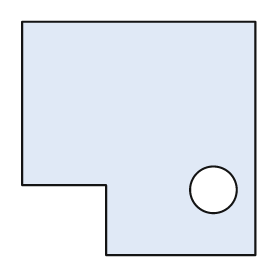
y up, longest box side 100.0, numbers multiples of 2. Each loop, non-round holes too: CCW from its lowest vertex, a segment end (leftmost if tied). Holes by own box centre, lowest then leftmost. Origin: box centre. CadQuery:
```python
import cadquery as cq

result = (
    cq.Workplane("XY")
    .moveTo(-14.0, -50.0)
    .lineTo(50.0, -50.0)
    .lineTo(50.0, 50.0)
    .lineTo(-50.0, 50.0)
    .lineTo(-50.0, -20.0)
    .lineTo(-14.0, -20.0)
    .close()
    .moveTo(32.0, -22.0)
    .circle(10.0)
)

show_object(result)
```